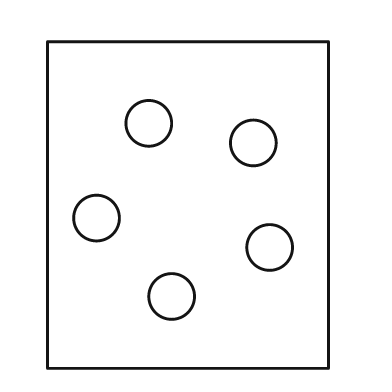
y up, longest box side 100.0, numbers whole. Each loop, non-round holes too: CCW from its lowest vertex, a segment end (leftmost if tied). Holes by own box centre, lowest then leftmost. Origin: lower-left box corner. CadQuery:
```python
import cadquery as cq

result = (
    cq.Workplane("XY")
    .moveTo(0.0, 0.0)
    .lineTo(86.0, 0.0)
    .lineTo(86.0, 100.0)
    .lineTo(0.0, 100.0)
    .close()
    .moveTo(38.0, 22.0)
    .circle(7.0)
    .moveTo(68.0, 37.0)
    .circle(7.0)
    .moveTo(15.0, 46.0)
    .circle(7.0)
    .moveTo(63.0, 69.0)
    .circle(7.0)
    .moveTo(31.0, 75.0)
    .circle(7.0)
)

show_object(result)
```